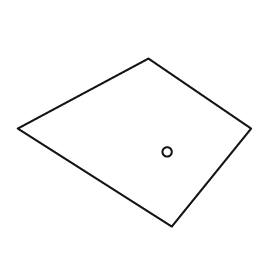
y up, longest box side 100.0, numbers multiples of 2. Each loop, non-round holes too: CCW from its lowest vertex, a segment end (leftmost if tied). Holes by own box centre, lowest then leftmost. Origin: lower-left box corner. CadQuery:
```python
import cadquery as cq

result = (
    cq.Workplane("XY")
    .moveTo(66.0, 0.0)
    .lineTo(100.0, 42.0)
    .lineTo(56.0, 72.0)
    .lineTo(0.0, 42.0)
    .close()
    .moveTo(64.0, 32.0)
    .circle(2.0)
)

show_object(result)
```